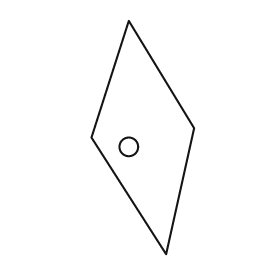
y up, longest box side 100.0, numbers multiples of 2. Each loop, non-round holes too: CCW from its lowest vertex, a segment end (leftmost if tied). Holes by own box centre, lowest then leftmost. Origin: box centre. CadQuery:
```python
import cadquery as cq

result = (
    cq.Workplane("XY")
    .moveTo(10.0, -50.0)
    .lineTo(22.0, 4.0)
    .lineTo(-6.0, 50.0)
    .lineTo(-22.0, 0.0)
    .close()
    .moveTo(-6.0, -4.0)
    .circle(4.0)
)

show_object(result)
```